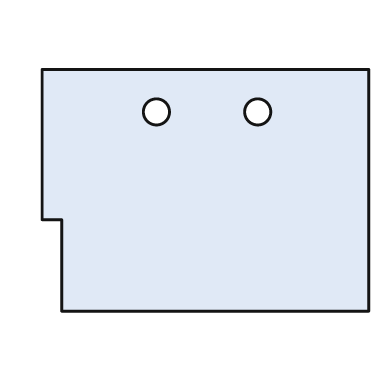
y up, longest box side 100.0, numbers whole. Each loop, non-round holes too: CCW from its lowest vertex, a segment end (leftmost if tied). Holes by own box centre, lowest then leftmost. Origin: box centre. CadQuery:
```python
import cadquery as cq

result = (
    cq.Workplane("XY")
    .moveTo(-44.0, -37.0)
    .lineTo(50.0, -37.0)
    .lineTo(50.0, 37.0)
    .lineTo(-50.0, 37.0)
    .lineTo(-50.0, -9.0)
    .lineTo(-44.0, -9.0)
    .close()
    .moveTo(-15.0, 24.0)
    .circle(4.0)
    .moveTo(16.0, 24.0)
    .circle(4.0)
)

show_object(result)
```